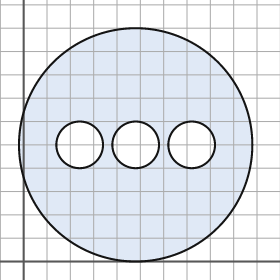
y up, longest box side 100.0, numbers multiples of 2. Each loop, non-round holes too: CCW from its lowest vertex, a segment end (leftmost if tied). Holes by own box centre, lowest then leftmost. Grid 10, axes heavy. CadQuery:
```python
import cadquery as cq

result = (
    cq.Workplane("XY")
    .moveTo(48.0, 50.0)
    .circle(50.0)
    .moveTo(24.0, 50.0)
    .circle(10.0)
    .moveTo(48.0, 50.0)
    .circle(10.0)
    .moveTo(72.0, 50.0)
    .circle(10.0)
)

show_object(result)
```